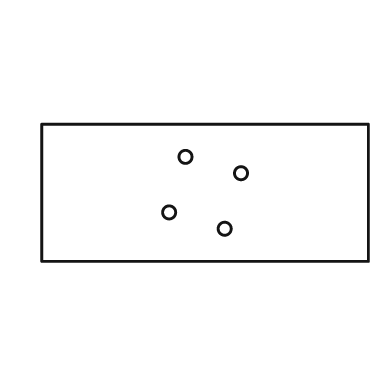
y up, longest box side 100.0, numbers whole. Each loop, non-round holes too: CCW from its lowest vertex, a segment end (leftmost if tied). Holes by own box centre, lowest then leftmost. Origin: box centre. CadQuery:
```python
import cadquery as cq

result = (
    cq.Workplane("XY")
    .moveTo(-50.0, -21.0)
    .lineTo(50.0, -21.0)
    .lineTo(50.0, 21.0)
    .lineTo(-50.0, 21.0)
    .close()
    .moveTo(6.0, -11.0)
    .circle(2.0)
    .moveTo(-11.0, -6.0)
    .circle(2.0)
    .moveTo(11.0, 6.0)
    .circle(2.0)
    .moveTo(-6.0, 11.0)
    .circle(2.0)
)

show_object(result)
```